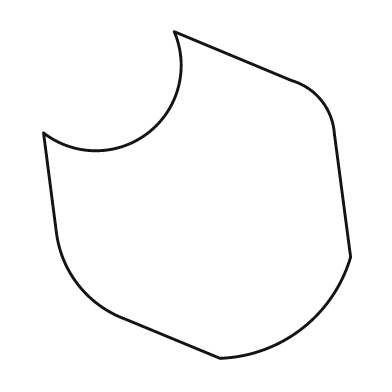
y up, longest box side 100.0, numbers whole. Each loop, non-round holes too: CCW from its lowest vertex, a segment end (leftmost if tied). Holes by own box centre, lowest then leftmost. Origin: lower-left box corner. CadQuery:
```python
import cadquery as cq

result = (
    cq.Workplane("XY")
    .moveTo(54.0, 0.0)
    .threePointArc((79.0, 9.0), (94.0, 31.0))
    .lineTo(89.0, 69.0)
    .threePointArc((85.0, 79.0), (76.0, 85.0))
    .lineTo(40.0, 100.0)
    .threePointArc((32.0, 69.0), (0.0, 69.0))
    .lineTo(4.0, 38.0)
    .threePointArc((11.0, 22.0), (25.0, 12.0))
    .close()
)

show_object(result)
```